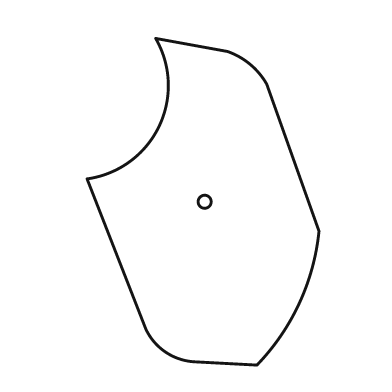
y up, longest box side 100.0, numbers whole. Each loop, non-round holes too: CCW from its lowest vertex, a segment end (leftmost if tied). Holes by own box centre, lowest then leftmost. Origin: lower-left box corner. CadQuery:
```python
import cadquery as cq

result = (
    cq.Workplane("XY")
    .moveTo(52.0, 0.0)
    .threePointArc((65.0, 19.0), (71.0, 41.0))
    .lineTo(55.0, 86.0)
    .threePointArc((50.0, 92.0), (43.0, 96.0))
    .lineTo(21.0, 100.0)
    .threePointArc((22.0, 73.0), (0.0, 57.0))
    .lineTo(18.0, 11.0)
    .threePointArc((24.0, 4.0), (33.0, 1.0))
    .close()
    .moveTo(36.0, 50.0)
    .circle(2.0)
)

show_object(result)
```